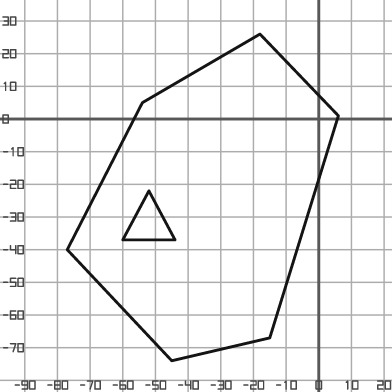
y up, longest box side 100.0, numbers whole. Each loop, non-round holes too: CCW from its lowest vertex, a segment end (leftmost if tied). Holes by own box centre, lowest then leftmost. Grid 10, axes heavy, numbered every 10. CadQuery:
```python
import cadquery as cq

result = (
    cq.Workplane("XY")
    .moveTo(-45.0, -74.0)
    .lineTo(-15.0, -67.0)
    .lineTo(6.0, 1.0)
    .lineTo(-18.0, 26.0)
    .lineTo(-54.0, 5.0)
    .lineTo(-77.0, -40.0)
    .close()
    .moveTo(-60.0, -37.0)
    .lineTo(-44.0, -37.0)
    .lineTo(-52.0, -22.0)
    .close()
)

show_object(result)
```